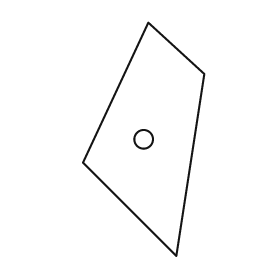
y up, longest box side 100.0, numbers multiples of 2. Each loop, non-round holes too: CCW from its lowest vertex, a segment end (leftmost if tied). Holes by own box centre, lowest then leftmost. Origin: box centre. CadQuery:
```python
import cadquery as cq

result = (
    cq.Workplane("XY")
    .moveTo(14.0, -50.0)
    .lineTo(26.0, 28.0)
    .lineTo(2.0, 50.0)
    .lineTo(-26.0, -10.0)
    .close()
    .moveTo(0.0, 0.0)
    .circle(4.0)
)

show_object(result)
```